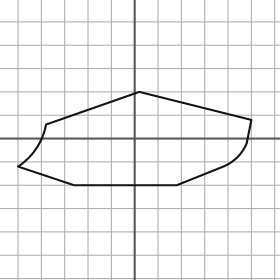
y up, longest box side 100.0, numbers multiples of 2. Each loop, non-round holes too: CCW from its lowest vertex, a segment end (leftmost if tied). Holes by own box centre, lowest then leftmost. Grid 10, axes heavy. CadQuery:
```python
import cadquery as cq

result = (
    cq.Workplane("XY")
    .moveTo(-26.0, -20.0)
    .lineTo(18.0, -20.0)
    .lineTo(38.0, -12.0)
    .threePointArc((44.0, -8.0), (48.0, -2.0))
    .lineTo(50.0, 8.0)
    .lineTo(2.0, 20.0)
    .lineTo(-38.0, 6.0)
    .threePointArc((-42.0, -4.0), (-50.0, -12.0))
    .close()
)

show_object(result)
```